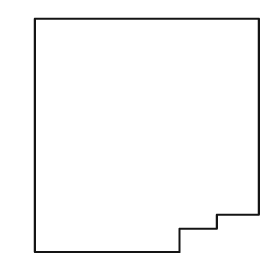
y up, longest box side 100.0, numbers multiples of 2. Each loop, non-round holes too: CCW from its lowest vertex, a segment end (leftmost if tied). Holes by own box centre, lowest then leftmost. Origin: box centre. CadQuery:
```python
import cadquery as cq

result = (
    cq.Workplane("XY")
    .moveTo(-48.0, -50.0)
    .lineTo(14.0, -50.0)
    .lineTo(14.0, -40.0)
    .lineTo(30.0, -40.0)
    .lineTo(30.0, -34.0)
    .lineTo(48.0, -34.0)
    .lineTo(48.0, 50.0)
    .lineTo(-48.0, 50.0)
    .close()
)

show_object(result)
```